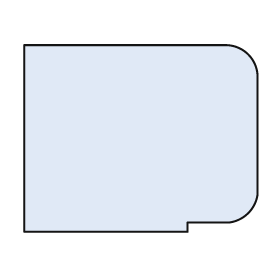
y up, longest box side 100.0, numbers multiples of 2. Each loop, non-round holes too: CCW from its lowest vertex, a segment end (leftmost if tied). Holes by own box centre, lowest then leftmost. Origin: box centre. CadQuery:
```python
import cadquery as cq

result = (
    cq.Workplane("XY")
    .moveTo(-50.0, -40.0)
    .lineTo(20.0, -40.0)
    .lineTo(20.0, -36.0)
    .lineTo(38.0, -36.0)
    .threePointArc((46.0, -32.0), (50.0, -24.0))
    .lineTo(50.0, 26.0)
    .threePointArc((46.0, 36.0), (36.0, 40.0))
    .lineTo(-50.0, 40.0)
    .close()
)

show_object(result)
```